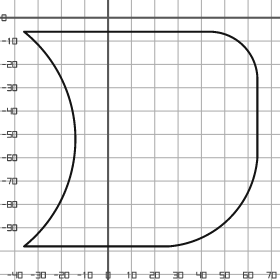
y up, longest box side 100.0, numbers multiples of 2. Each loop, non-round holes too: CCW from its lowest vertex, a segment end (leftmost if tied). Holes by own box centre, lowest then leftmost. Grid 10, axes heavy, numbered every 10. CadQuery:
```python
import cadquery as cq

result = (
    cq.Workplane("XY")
    .moveTo(-36.0, -98.0)
    .lineTo(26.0, -98.0)
    .threePointArc((52.0, -86.0), (64.0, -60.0))
    .lineTo(64.0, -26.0)
    .threePointArc((58.0, -12.0), (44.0, -6.0))
    .lineTo(-36.0, -6.0)
    .threePointArc((-14.0, -52.0), (-36.0, -98.0))
    .close()
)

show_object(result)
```